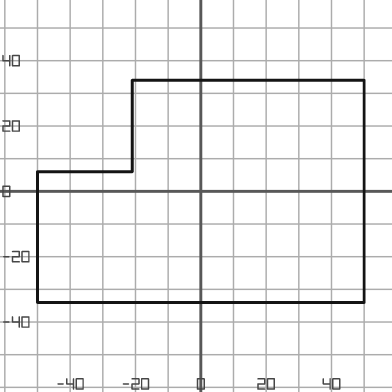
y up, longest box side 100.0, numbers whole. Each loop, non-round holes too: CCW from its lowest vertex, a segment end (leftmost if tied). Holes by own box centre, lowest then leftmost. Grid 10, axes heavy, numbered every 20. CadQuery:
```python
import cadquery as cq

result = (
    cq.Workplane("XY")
    .moveTo(-50.0, -34.0)
    .lineTo(50.0, -34.0)
    .lineTo(50.0, 34.0)
    .lineTo(-21.0, 34.0)
    .lineTo(-21.0, 6.0)
    .lineTo(-50.0, 6.0)
    .close()
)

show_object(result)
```